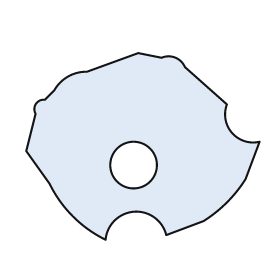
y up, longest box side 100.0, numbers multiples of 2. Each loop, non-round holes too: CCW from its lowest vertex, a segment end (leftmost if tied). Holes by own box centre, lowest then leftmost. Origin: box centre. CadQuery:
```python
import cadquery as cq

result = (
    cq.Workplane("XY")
    .moveTo(-16.0, -40.0)
    .threePointArc((-4.0, -28.0), (10.0, -38.0))
    .lineTo(26.0, -32.0)
    .threePointArc((36.0, -24.0), (44.0, -14.0))
    .lineTo(50.0, 2.0)
    .threePointArc((38.0, 6.0), (36.0, 18.0))
    .lineTo(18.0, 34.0)
    .threePointArc((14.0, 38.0), (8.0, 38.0))
    .lineTo(-2.0, 40.0)
    .lineTo(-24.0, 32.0)
    .threePointArc((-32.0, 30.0), (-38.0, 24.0))
    .lineTo(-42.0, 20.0)
    .threePointArc((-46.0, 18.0), (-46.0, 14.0))
    .lineTo(-50.0, -2.0)
    .lineTo(-40.0, -16.0)
    .threePointArc((-30.0, -30.0), (-16.0, -40.0))
    .close()
    .moveTo(-4.0, -8.0)
    .circle(10.0)
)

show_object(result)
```